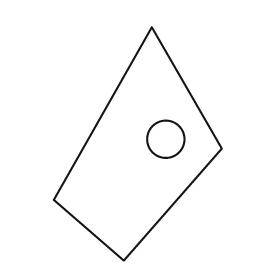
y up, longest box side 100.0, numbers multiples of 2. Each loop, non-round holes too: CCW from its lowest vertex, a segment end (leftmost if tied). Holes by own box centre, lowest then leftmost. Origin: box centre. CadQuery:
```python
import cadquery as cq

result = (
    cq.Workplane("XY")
    .moveTo(-6.0, -50.0)
    .lineTo(36.0, -2.0)
    .lineTo(6.0, 50.0)
    .lineTo(-36.0, -24.0)
    .close()
    .moveTo(12.0, 2.0)
    .circle(8.0)
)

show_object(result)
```